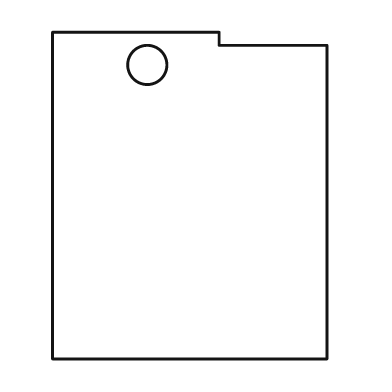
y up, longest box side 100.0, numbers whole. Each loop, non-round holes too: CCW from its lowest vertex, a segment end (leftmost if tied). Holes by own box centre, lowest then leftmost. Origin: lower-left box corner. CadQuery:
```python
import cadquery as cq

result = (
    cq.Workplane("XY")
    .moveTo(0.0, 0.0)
    .lineTo(84.0, 0.0)
    .lineTo(84.0, 96.0)
    .lineTo(51.0, 96.0)
    .lineTo(51.0, 100.0)
    .lineTo(0.0, 100.0)
    .close()
    .moveTo(29.0, 90.0)
    .circle(6.0)
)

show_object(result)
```